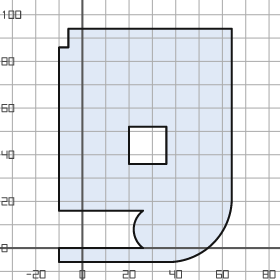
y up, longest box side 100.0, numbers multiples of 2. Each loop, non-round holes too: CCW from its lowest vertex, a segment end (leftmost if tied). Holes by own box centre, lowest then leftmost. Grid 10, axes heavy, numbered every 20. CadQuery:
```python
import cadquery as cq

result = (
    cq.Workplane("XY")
    .moveTo(-10.0, -6.0)
    .lineTo(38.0, -6.0)
    .threePointArc((56.0, 2.0), (64.0, 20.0))
    .lineTo(64.0, 94.0)
    .lineTo(-6.0, 94.0)
    .lineTo(-6.0, 86.0)
    .lineTo(-10.0, 86.0)
    .lineTo(-10.0, 16.0)
    .lineTo(26.0, 16.0)
    .threePointArc((22.0, 8.0), (26.0, 0.0))
    .lineTo(-10.0, 0.0)
    .close()
    .moveTo(20.0, 36.0)
    .lineTo(36.0, 36.0)
    .lineTo(36.0, 52.0)
    .lineTo(20.0, 52.0)
    .close()
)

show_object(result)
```